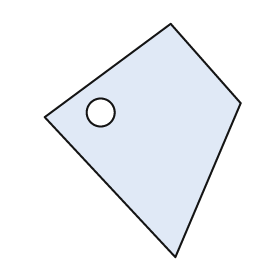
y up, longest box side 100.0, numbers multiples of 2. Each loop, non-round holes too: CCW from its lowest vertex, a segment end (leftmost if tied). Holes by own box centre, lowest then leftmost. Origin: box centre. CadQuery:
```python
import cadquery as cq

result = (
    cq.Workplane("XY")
    .moveTo(14.0, -50.0)
    .lineTo(42.0, 16.0)
    .lineTo(12.0, 50.0)
    .lineTo(-42.0, 10.0)
    .close()
    .moveTo(-18.0, 12.0)
    .circle(6.0)
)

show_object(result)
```